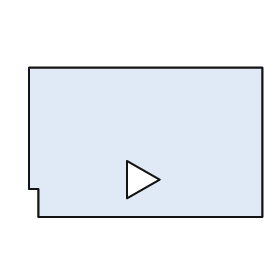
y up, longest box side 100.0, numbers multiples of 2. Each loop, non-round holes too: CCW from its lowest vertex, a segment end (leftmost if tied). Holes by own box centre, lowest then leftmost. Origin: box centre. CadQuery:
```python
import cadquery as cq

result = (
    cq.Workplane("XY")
    .moveTo(-46.0, -32.0)
    .lineTo(50.0, -32.0)
    .lineTo(50.0, 32.0)
    .lineTo(-50.0, 32.0)
    .lineTo(-50.0, -20.0)
    .lineTo(-46.0, -20.0)
    .close()
    .moveTo(-8.0, -24.0)
    .lineTo(6.0, -16.0)
    .lineTo(-8.0, -8.0)
    .close()
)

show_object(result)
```